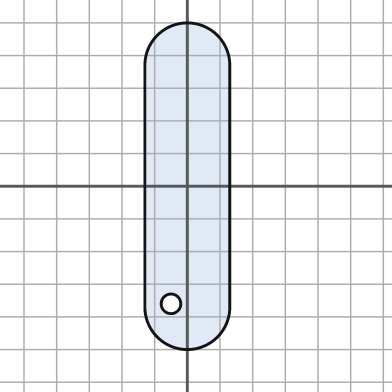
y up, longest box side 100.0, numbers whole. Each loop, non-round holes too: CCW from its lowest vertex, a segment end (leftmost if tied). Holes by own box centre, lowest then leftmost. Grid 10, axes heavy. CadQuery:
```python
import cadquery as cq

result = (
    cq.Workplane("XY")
    .moveTo(-13.0, -37.0)
    .threePointArc((0.0, -50.0), (13.0, -37.0))
    .lineTo(13.0, 37.0)
    .threePointArc((0.0, 50.0), (-13.0, 37.0))
    .close()
    .moveTo(-5.0, -36.0)
    .circle(3.0)
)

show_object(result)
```